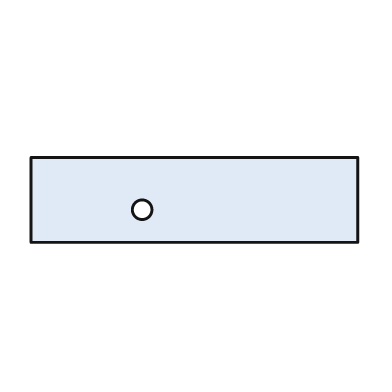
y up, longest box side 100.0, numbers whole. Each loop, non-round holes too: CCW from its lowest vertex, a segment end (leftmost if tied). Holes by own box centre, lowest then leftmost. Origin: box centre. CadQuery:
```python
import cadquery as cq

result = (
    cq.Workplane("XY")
    .moveTo(-50.0, -13.0)
    .lineTo(50.0, -13.0)
    .lineTo(50.0, 13.0)
    .lineTo(-50.0, 13.0)
    .close()
    .moveTo(-16.0, -3.0)
    .circle(3.0)
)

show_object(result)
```